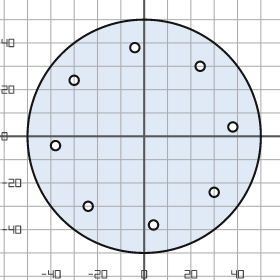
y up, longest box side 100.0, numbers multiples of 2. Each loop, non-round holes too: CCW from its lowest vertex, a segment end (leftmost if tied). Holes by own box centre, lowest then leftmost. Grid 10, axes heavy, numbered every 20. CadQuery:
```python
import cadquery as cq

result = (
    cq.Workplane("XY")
    .moveTo(0.0, 0.0)
    .circle(50.0)
    .moveTo(4.0, -38.0)
    .circle(2.0)
    .moveTo(-24.0, -30.0)
    .circle(2.0)
    .moveTo(30.0, -24.0)
    .circle(2.0)
    .moveTo(-38.0, -4.0)
    .circle(2.0)
    .moveTo(38.0, 4.0)
    .circle(2.0)
    .moveTo(-30.0, 24.0)
    .circle(2.0)
    .moveTo(24.0, 30.0)
    .circle(2.0)
    .moveTo(-4.0, 38.0)
    .circle(2.0)
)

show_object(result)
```